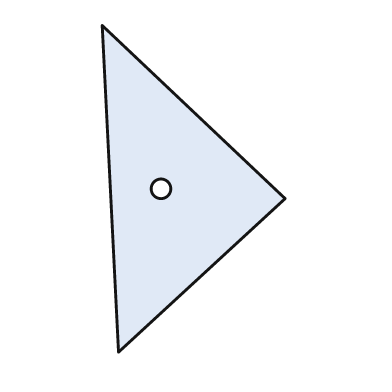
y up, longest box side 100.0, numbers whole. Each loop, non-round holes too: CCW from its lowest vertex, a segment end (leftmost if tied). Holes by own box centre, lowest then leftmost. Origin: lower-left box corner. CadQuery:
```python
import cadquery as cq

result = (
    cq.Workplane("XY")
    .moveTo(5.0, 0.0)
    .lineTo(56.0, 47.0)
    .lineTo(0.0, 100.0)
    .close()
    .moveTo(18.0, 50.0)
    .circle(3.0)
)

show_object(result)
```